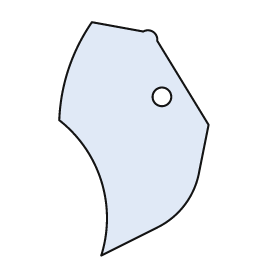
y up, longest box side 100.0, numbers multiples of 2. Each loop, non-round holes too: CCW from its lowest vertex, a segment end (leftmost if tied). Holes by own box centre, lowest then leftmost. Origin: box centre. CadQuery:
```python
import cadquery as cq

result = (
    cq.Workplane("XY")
    .moveTo(-14.0, -50.0)
    .lineTo(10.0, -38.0)
    .threePointArc((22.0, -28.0), (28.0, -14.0))
    .lineTo(32.0, 6.0)
    .lineTo(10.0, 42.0)
    .threePointArc((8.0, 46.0), (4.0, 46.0))
    .lineTo(-18.0, 50.0)
    .threePointArc((-28.0, 30.0), (-32.0, 8.0))
    .threePointArc((-14.0, -18.0), (-14.0, -50.0))
    .close()
    .moveTo(12.0, 18.0)
    .circle(4.0)
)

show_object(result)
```